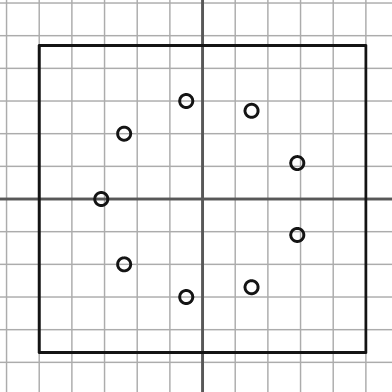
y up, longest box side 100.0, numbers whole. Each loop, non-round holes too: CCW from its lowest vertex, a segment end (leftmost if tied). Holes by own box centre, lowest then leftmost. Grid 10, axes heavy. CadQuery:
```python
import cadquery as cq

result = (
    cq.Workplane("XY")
    .moveTo(-50.0, -47.0)
    .lineTo(50.0, -47.0)
    .lineTo(50.0, 47.0)
    .lineTo(-50.0, 47.0)
    .close()
    .moveTo(-5.0, -30.0)
    .circle(2.0)
    .moveTo(15.0, -27.0)
    .circle(2.0)
    .moveTo(-24.0, -20.0)
    .circle(2.0)
    .moveTo(29.0, -11.0)
    .circle(2.0)
    .moveTo(-31.0, 0.0)
    .circle(2.0)
    .moveTo(29.0, 11.0)
    .circle(2.0)
    .moveTo(-24.0, 20.0)
    .circle(2.0)
    .moveTo(15.0, 27.0)
    .circle(2.0)
    .moveTo(-5.0, 30.0)
    .circle(2.0)
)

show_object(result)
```